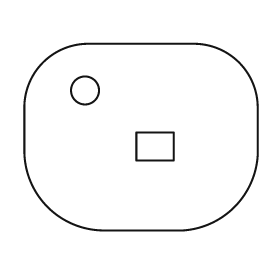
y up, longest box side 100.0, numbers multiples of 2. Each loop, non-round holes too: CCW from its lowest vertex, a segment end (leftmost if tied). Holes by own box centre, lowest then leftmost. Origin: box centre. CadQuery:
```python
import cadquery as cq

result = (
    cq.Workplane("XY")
    .moveTo(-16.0, -40.0)
    .lineTo(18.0, -40.0)
    .threePointArc((40.0, -30.0), (50.0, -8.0))
    .lineTo(50.0, 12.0)
    .threePointArc((42.0, 32.0), (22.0, 40.0))
    .lineTo(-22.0, 40.0)
    .threePointArc((-42.0, 32.0), (-50.0, 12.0))
    .lineTo(-50.0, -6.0)
    .threePointArc((-40.0, -30.0), (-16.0, -40.0))
    .close()
    .moveTo(-2.0, -10.0)
    .lineTo(14.0, -10.0)
    .lineTo(14.0, 2.0)
    .lineTo(-2.0, 2.0)
    .close()
    .moveTo(-24.0, 20.0)
    .circle(6.0)
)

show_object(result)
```